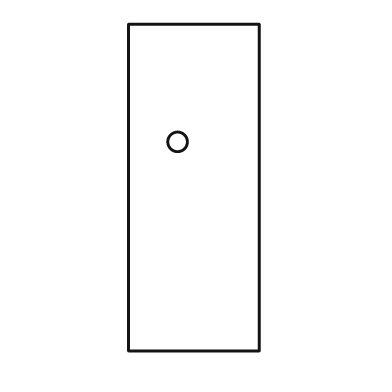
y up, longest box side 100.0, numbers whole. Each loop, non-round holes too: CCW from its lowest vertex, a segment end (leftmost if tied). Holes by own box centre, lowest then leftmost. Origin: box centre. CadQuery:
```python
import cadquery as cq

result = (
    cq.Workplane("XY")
    .moveTo(-20.0, -50.0)
    .lineTo(20.0, -50.0)
    .lineTo(20.0, 50.0)
    .lineTo(-20.0, 50.0)
    .close()
    .moveTo(-5.0, 14.0)
    .circle(3.0)
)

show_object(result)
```